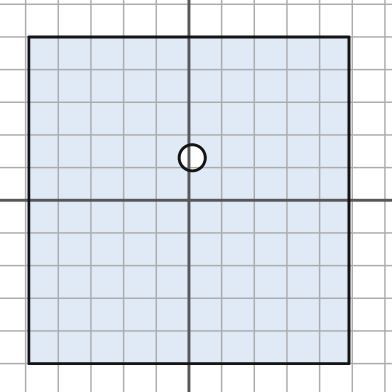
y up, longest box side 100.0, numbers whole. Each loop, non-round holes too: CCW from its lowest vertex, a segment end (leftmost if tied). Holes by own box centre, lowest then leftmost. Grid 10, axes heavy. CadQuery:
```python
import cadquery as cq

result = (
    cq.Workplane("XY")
    .moveTo(-49.0, -50.0)
    .lineTo(49.0, -50.0)
    .lineTo(49.0, 50.0)
    .lineTo(-49.0, 50.0)
    .close()
    .moveTo(1.0, 13.0)
    .circle(4.0)
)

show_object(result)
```